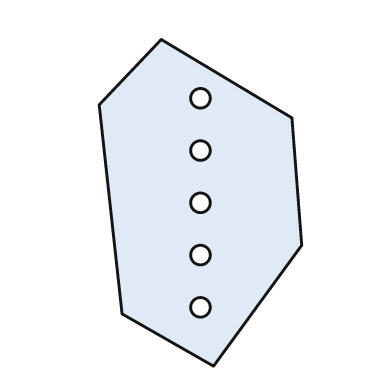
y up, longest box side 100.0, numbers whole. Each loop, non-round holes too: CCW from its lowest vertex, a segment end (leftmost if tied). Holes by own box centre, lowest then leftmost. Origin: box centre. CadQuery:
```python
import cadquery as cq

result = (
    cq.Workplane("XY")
    .moveTo(4.0, -50.0)
    .lineTo(31.0, -13.0)
    .lineTo(28.0, 26.0)
    .lineTo(-12.0, 50.0)
    .lineTo(-31.0, 30.0)
    .lineTo(-24.0, -34.0)
    .close()
    .moveTo(0.0, -32.0)
    .circle(3.0)
    .moveTo(0.0, -16.0)
    .circle(3.0)
    .moveTo(0.0, 0.0)
    .circle(3.0)
    .moveTo(0.0, 16.0)
    .circle(3.0)
    .moveTo(0.0, 32.0)
    .circle(3.0)
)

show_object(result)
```